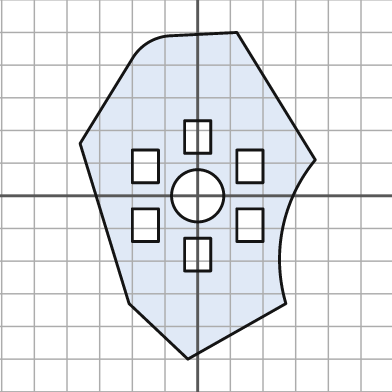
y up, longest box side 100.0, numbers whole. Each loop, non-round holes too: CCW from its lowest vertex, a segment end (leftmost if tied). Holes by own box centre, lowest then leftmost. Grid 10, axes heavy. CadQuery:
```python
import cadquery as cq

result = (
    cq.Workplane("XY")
    .moveTo(-3.0, -50.0)
    .lineTo(27.0, -33.0)
    .threePointArc((26.0, -10.0), (36.0, 11.0))
    .lineTo(12.0, 50.0)
    .lineTo(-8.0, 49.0)
    .threePointArc((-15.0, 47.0), (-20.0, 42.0))
    .lineTo(-36.0, 16.0)
    .lineTo(-21.0, -33.0)
    .close()
    .moveTo(-4.0, -23.0)
    .lineTo(4.0, -23.0)
    .lineTo(4.0, -13.0)
    .lineTo(-4.0, -13.0)
    .close()
    .moveTo(-20.0, -14.0)
    .lineTo(-12.0, -14.0)
    .lineTo(-12.0, -4.0)
    .lineTo(-20.0, -4.0)
    .close()
    .moveTo(12.0, -14.0)
    .lineTo(20.0, -14.0)
    .lineTo(20.0, -4.0)
    .lineTo(12.0, -4.0)
    .close()
    .moveTo(0.0, 0.0)
    .circle(8.0)
    .moveTo(-20.0, 4.0)
    .lineTo(-12.0, 4.0)
    .lineTo(-12.0, 14.0)
    .lineTo(-20.0, 14.0)
    .close()
    .moveTo(12.0, 4.0)
    .lineTo(20.0, 4.0)
    .lineTo(20.0, 14.0)
    .lineTo(12.0, 14.0)
    .close()
    .moveTo(-4.0, 13.0)
    .lineTo(4.0, 13.0)
    .lineTo(4.0, 23.0)
    .lineTo(-4.0, 23.0)
    .close()
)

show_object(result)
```